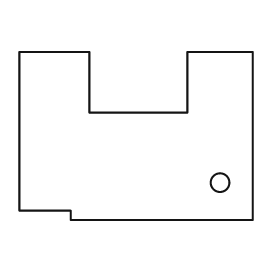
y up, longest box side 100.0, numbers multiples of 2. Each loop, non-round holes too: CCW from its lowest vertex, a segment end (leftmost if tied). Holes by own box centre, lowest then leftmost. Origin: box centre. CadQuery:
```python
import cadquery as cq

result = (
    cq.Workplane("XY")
    .moveTo(-28.0, -36.0)
    .lineTo(50.0, -36.0)
    .lineTo(50.0, 36.0)
    .lineTo(22.0, 36.0)
    .lineTo(22.0, 10.0)
    .lineTo(-20.0, 10.0)
    .lineTo(-20.0, 36.0)
    .lineTo(-50.0, 36.0)
    .lineTo(-50.0, -32.0)
    .lineTo(-28.0, -32.0)
    .close()
    .moveTo(36.0, -20.0)
    .circle(4.0)
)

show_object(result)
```